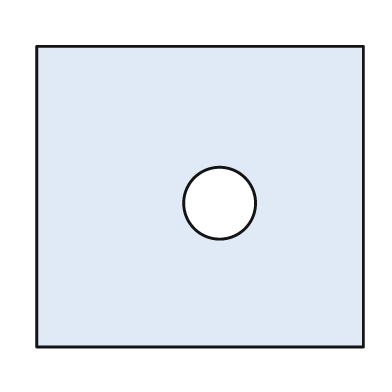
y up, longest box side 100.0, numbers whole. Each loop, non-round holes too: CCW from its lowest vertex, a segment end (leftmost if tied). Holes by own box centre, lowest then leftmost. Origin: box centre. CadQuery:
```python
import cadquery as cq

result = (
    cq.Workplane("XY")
    .moveTo(-50.0, -46.0)
    .lineTo(50.0, -46.0)
    .lineTo(50.0, 46.0)
    .lineTo(-50.0, 46.0)
    .close()
    .moveTo(6.0, -2.0)
    .circle(11.0)
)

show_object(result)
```